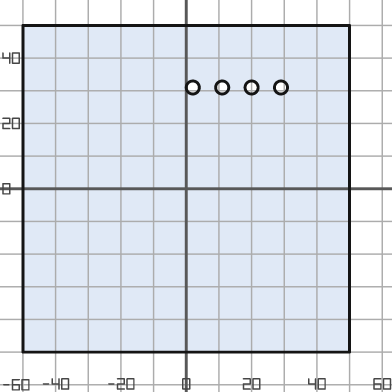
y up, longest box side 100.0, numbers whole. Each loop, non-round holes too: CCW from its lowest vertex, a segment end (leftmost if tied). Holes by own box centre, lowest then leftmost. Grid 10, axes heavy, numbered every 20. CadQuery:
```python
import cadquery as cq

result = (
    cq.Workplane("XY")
    .moveTo(-50.0, -50.0)
    .lineTo(50.0, -50.0)
    .lineTo(50.0, 50.0)
    .lineTo(-50.0, 50.0)
    .close()
    .moveTo(2.0, 31.0)
    .circle(2.0)
    .moveTo(11.0, 31.0)
    .circle(2.0)
    .moveTo(20.0, 31.0)
    .circle(2.0)
    .moveTo(29.0, 31.0)
    .circle(2.0)
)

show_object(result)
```